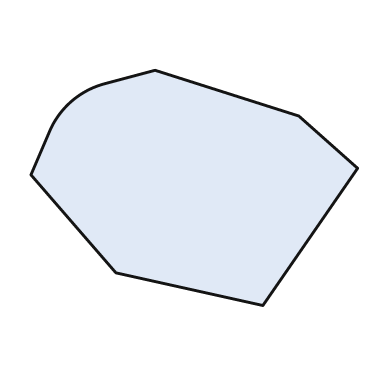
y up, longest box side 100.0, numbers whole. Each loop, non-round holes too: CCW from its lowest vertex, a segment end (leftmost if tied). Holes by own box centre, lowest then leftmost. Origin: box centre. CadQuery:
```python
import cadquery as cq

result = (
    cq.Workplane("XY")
    .moveTo(21.0, -36.0)
    .lineTo(50.0, 6.0)
    .lineTo(32.0, 22.0)
    .lineTo(-12.0, 36.0)
    .lineTo(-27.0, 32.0)
    .threePointArc((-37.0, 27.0), (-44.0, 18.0))
    .lineTo(-50.0, 4.0)
    .lineTo(-24.0, -26.0)
    .close()
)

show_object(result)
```